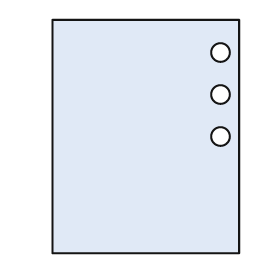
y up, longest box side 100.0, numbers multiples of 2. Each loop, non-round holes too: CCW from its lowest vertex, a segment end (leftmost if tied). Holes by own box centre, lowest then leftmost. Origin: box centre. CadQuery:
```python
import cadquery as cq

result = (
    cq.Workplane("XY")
    .moveTo(-40.0, -50.0)
    .lineTo(40.0, -50.0)
    .lineTo(40.0, 50.0)
    .lineTo(-40.0, 50.0)
    .close()
    .moveTo(32.0, 0.0)
    .circle(4.0)
    .moveTo(32.0, 18.0)
    .circle(4.0)
    .moveTo(32.0, 36.0)
    .circle(4.0)
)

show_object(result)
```